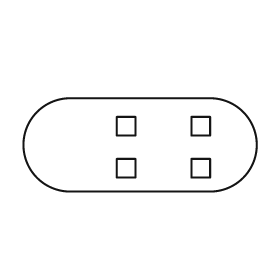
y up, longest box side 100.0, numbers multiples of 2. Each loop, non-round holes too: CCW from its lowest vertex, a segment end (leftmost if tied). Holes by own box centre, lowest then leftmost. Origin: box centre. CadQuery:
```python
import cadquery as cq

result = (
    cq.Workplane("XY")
    .moveTo(-30.0, -20.0)
    .lineTo(30.0, -20.0)
    .threePointArc((50.0, 0.0), (30.0, 20.0))
    .lineTo(-30.0, 20.0)
    .threePointArc((-50.0, 0.0), (-30.0, -20.0))
    .close()
    .moveTo(-10.0, -14.0)
    .lineTo(-2.0, -14.0)
    .lineTo(-2.0, -6.0)
    .lineTo(-10.0, -6.0)
    .close()
    .moveTo(22.0, -14.0)
    .lineTo(30.0, -14.0)
    .lineTo(30.0, -6.0)
    .lineTo(22.0, -6.0)
    .close()
    .moveTo(-10.0, 4.0)
    .lineTo(-2.0, 4.0)
    .lineTo(-2.0, 12.0)
    .lineTo(-10.0, 12.0)
    .close()
    .moveTo(22.0, 4.0)
    .lineTo(30.0, 4.0)
    .lineTo(30.0, 12.0)
    .lineTo(22.0, 12.0)
    .close()
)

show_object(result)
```